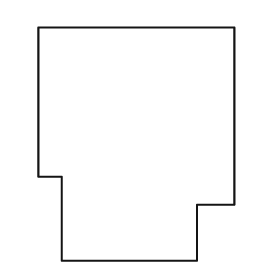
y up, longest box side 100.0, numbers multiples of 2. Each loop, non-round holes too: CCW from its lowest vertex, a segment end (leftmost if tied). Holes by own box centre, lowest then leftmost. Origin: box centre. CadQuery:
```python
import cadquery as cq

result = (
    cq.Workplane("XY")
    .moveTo(-32.0, -50.0)
    .lineTo(26.0, -50.0)
    .lineTo(26.0, -26.0)
    .lineTo(42.0, -26.0)
    .lineTo(42.0, 50.0)
    .lineTo(-42.0, 50.0)
    .lineTo(-42.0, -14.0)
    .lineTo(-32.0, -14.0)
    .close()
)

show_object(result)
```